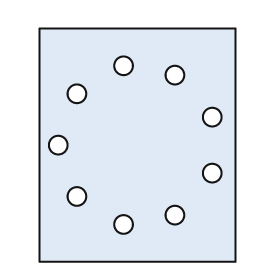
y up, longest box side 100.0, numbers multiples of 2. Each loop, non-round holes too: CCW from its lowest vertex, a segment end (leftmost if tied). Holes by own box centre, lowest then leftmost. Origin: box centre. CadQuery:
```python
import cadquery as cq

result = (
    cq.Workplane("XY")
    .moveTo(-42.0, -50.0)
    .lineTo(42.0, -50.0)
    .lineTo(42.0, 50.0)
    .lineTo(-42.0, 50.0)
    .close()
    .moveTo(-6.0, -34.0)
    .circle(4.0)
    .moveTo(16.0, -30.0)
    .circle(4.0)
    .moveTo(-26.0, -22.0)
    .circle(4.0)
    .moveTo(32.0, -12.0)
    .circle(4.0)
    .moveTo(-34.0, 0.0)
    .circle(4.0)
    .moveTo(32.0, 12.0)
    .circle(4.0)
    .moveTo(-26.0, 22.0)
    .circle(4.0)
    .moveTo(16.0, 30.0)
    .circle(4.0)
    .moveTo(-6.0, 34.0)
    .circle(4.0)
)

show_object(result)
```